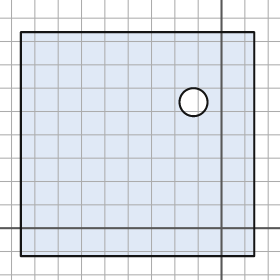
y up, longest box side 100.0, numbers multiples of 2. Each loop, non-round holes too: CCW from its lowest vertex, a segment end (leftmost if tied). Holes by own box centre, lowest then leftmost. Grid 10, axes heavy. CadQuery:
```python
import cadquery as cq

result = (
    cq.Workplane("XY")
    .moveTo(-86.0, -12.0)
    .lineTo(14.0, -12.0)
    .lineTo(14.0, 84.0)
    .lineTo(-86.0, 84.0)
    .close()
    .moveTo(-12.0, 54.0)
    .circle(6.0)
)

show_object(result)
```